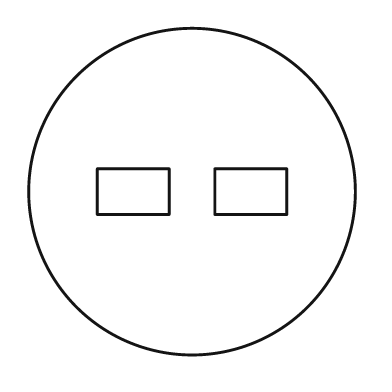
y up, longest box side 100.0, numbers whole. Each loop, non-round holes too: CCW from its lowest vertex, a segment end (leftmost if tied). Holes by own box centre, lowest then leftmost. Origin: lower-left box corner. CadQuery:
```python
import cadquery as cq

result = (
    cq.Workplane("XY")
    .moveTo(50.0, 50.0)
    .circle(50.0)
    .moveTo(21.0, 43.0)
    .lineTo(43.0, 43.0)
    .lineTo(43.0, 57.0)
    .lineTo(21.0, 57.0)
    .close()
    .moveTo(57.0, 43.0)
    .lineTo(79.0, 43.0)
    .lineTo(79.0, 57.0)
    .lineTo(57.0, 57.0)
    .close()
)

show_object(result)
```